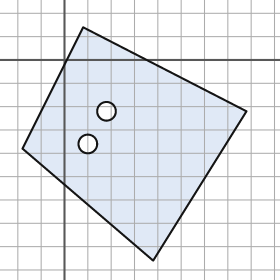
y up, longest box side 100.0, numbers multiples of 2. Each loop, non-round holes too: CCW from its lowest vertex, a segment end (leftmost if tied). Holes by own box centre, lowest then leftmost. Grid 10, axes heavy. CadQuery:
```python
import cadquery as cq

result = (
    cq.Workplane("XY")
    .moveTo(38.0, -86.0)
    .lineTo(78.0, -22.0)
    .lineTo(8.0, 14.0)
    .lineTo(-18.0, -38.0)
    .close()
    .moveTo(10.0, -36.0)
    .circle(4.0)
    .moveTo(18.0, -22.0)
    .circle(4.0)
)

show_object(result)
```